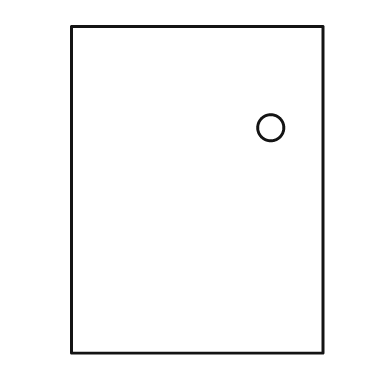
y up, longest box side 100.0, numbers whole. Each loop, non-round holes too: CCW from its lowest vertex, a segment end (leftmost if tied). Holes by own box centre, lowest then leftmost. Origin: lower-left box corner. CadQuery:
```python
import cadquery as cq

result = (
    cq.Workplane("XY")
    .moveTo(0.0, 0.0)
    .lineTo(77.0, 0.0)
    .lineTo(77.0, 100.0)
    .lineTo(0.0, 100.0)
    .close()
    .moveTo(61.0, 69.0)
    .circle(4.0)
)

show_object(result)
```